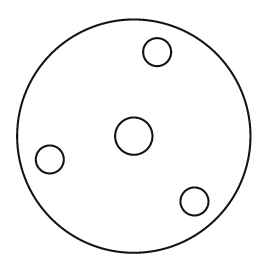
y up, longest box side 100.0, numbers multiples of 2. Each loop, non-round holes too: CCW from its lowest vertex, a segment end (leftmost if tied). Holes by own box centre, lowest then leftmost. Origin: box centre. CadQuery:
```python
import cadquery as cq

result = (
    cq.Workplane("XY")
    .moveTo(0.0, 0.0)
    .circle(50.0)
    .moveTo(26.0, -28.0)
    .circle(6.0)
    .moveTo(-36.0, -10.0)
    .circle(6.0)
    .moveTo(0.0, 0.0)
    .circle(8.0)
    .moveTo(10.0, 36.0)
    .circle(6.0)
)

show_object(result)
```